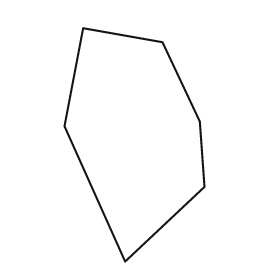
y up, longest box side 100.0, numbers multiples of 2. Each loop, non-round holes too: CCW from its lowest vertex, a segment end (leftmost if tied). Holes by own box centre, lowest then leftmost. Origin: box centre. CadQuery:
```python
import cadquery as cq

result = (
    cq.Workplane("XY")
    .moveTo(-4.0, -50.0)
    .lineTo(30.0, -18.0)
    .lineTo(28.0, 10.0)
    .lineTo(12.0, 44.0)
    .lineTo(-22.0, 50.0)
    .lineTo(-30.0, 8.0)
    .close()
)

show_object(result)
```